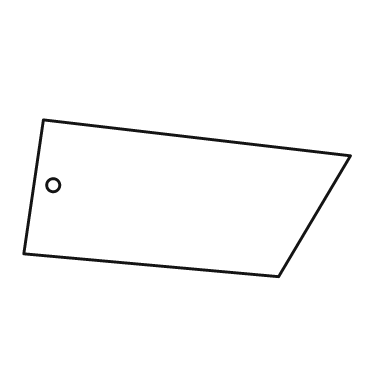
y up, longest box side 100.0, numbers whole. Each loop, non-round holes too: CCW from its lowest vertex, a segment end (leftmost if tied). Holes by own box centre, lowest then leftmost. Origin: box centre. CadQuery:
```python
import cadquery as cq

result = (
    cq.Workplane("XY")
    .moveTo(28.0, -24.0)
    .lineTo(50.0, 13.0)
    .lineTo(-44.0, 24.0)
    .lineTo(-50.0, -17.0)
    .close()
    .moveTo(-41.0, 4.0)
    .circle(2.0)
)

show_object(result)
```